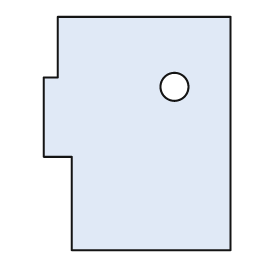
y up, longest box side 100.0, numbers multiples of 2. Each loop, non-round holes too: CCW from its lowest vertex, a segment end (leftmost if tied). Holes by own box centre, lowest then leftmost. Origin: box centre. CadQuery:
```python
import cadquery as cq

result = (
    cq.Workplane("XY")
    .moveTo(-28.0, -50.0)
    .lineTo(40.0, -50.0)
    .lineTo(40.0, 50.0)
    .lineTo(-34.0, 50.0)
    .lineTo(-34.0, 24.0)
    .lineTo(-40.0, 24.0)
    .lineTo(-40.0, -10.0)
    .lineTo(-28.0, -10.0)
    .close()
    .moveTo(16.0, 20.0)
    .circle(6.0)
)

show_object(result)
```